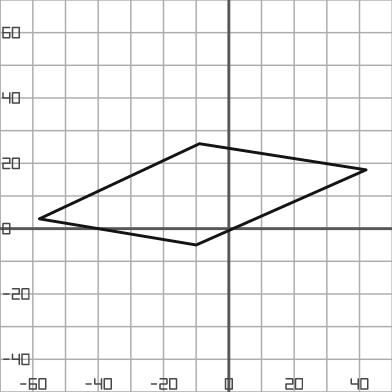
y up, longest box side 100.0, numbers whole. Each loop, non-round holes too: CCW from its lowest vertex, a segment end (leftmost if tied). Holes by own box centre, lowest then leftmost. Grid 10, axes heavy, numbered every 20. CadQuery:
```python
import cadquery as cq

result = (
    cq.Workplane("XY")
    .moveTo(-10.0, -5.0)
    .lineTo(42.0, 18.0)
    .lineTo(-9.0, 26.0)
    .lineTo(-58.0, 3.0)
    .close()
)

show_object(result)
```